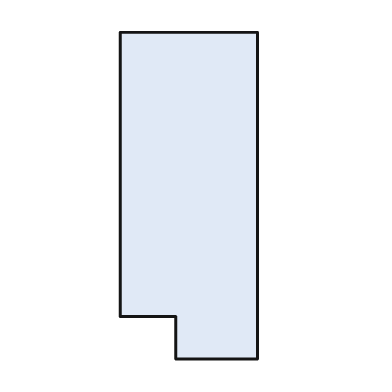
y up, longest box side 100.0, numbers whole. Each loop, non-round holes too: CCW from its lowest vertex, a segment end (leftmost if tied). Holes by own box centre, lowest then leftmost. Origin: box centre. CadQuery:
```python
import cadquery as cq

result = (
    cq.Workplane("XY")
    .moveTo(-4.0, -50.0)
    .lineTo(21.0, -50.0)
    .lineTo(21.0, 50.0)
    .lineTo(-21.0, 50.0)
    .lineTo(-21.0, -37.0)
    .lineTo(-4.0, -37.0)
    .close()
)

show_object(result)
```